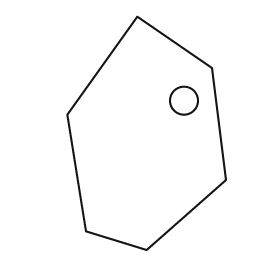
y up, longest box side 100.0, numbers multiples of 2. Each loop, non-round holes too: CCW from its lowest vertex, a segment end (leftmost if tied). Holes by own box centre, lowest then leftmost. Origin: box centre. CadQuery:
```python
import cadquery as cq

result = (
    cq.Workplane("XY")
    .moveTo(0.0, -50.0)
    .lineTo(34.0, -20.0)
    .lineTo(28.0, 28.0)
    .lineTo(-4.0, 50.0)
    .lineTo(-34.0, 8.0)
    .lineTo(-26.0, -42.0)
    .close()
    .moveTo(16.0, 14.0)
    .circle(6.0)
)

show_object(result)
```